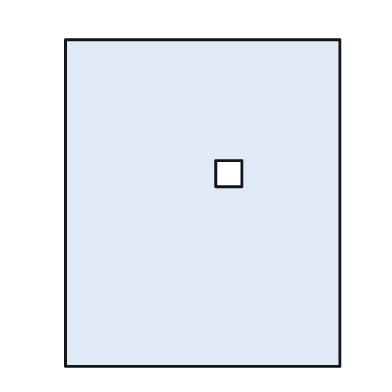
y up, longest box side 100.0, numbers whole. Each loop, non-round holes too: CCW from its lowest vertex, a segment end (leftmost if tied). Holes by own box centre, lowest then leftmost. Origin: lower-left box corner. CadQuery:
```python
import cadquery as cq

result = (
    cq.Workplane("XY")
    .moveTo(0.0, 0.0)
    .lineTo(84.0, 0.0)
    .lineTo(84.0, 100.0)
    .lineTo(0.0, 100.0)
    .close()
    .moveTo(46.0, 55.0)
    .lineTo(54.0, 55.0)
    .lineTo(54.0, 63.0)
    .lineTo(46.0, 63.0)
    .close()
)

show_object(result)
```